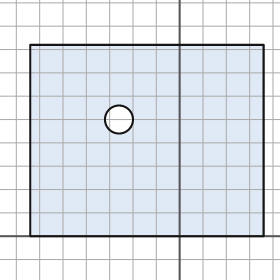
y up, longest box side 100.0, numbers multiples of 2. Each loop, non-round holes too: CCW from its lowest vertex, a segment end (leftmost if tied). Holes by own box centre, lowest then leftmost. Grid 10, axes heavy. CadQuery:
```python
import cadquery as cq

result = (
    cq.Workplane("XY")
    .moveTo(-64.0, 0.0)
    .lineTo(36.0, 0.0)
    .lineTo(36.0, 82.0)
    .lineTo(-64.0, 82.0)
    .close()
    .moveTo(-26.0, 50.0)
    .circle(6.0)
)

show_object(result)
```